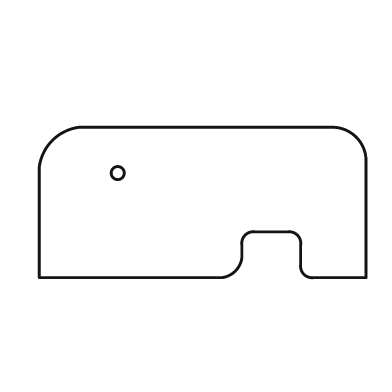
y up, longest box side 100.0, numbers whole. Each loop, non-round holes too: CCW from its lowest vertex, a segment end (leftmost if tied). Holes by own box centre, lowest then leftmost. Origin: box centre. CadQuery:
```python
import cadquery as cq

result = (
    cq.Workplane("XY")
    .moveTo(-50.0, -23.0)
    .lineTo(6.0, -23.0)
    .threePointArc((10.0, -21.0), (12.0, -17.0))
    .lineTo(12.0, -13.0)
    .threePointArc((13.0, -10.0), (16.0, -9.0))
    .lineTo(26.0, -9.0)
    .threePointArc((29.0, -10.0), (30.0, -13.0))
    .lineTo(30.0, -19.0)
    .threePointArc((31.0, -22.0), (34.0, -23.0))
    .lineTo(50.0, -23.0)
    .lineTo(50.0, 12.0)
    .threePointArc((47.0, 20.0), (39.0, 23.0))
    .lineTo(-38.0, 23.0)
    .threePointArc((-46.0, 19.0), (-50.0, 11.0))
    .close()
    .moveTo(-26.0, 9.0)
    .circle(2.0)
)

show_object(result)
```